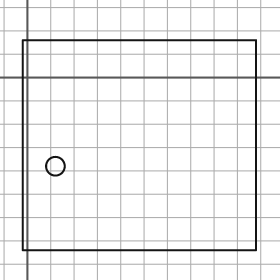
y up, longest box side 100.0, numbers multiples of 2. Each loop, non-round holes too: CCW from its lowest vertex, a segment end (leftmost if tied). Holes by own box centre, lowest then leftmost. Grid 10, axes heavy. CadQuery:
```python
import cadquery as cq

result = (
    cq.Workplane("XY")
    .moveTo(-2.0, -74.0)
    .lineTo(98.0, -74.0)
    .lineTo(98.0, 16.0)
    .lineTo(-2.0, 16.0)
    .close()
    .moveTo(12.0, -38.0)
    .circle(4.0)
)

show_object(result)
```